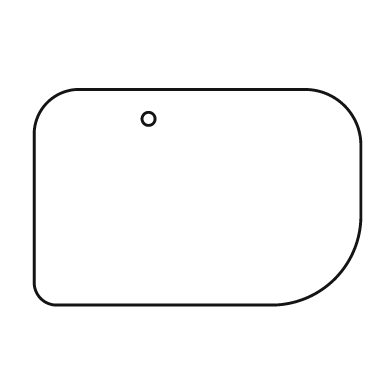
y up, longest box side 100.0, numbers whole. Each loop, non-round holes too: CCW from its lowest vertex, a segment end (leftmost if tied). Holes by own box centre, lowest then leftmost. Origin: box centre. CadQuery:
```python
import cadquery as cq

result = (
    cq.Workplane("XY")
    .moveTo(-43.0, -33.0)
    .lineTo(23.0, -33.0)
    .threePointArc((42.0, -25.0), (50.0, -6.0))
    .lineTo(50.0, 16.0)
    .threePointArc((45.0, 28.0), (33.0, 33.0))
    .lineTo(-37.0, 33.0)
    .threePointArc((-46.0, 29.0), (-50.0, 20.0))
    .lineTo(-50.0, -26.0)
    .threePointArc((-48.0, -31.0), (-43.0, -33.0))
    .close()
    .moveTo(-15.0, 24.0)
    .circle(2.0)
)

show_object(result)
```